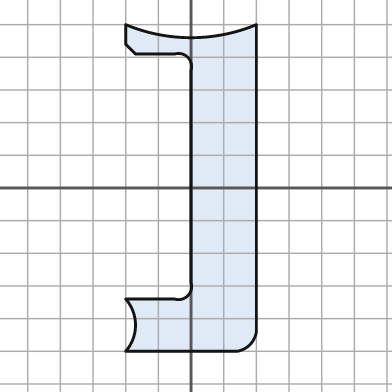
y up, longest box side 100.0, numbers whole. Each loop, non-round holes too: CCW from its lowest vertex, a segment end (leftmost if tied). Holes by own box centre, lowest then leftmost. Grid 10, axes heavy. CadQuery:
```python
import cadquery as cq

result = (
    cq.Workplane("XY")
    .moveTo(-20.0, -50.0)
    .lineTo(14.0, -50.0)
    .threePointArc((18.0, -48.0), (20.0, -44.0))
    .lineTo(20.0, 50.0)
    .threePointArc((0.0, 46.0), (-20.0, 50.0))
    .lineTo(-20.0, 44.0)
    .lineTo(-17.0, 41.0)
    .lineTo(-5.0, 41.0)
    .threePointArc((-1.0, 40.0), (0.0, 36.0))
    .lineTo(0.0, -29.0)
    .threePointArc((-1.0, -33.0), (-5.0, -34.0))
    .lineTo(-20.0, -34.0)
    .threePointArc((-17.0, -42.0), (-20.0, -50.0))
    .close()
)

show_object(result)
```